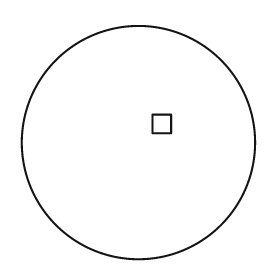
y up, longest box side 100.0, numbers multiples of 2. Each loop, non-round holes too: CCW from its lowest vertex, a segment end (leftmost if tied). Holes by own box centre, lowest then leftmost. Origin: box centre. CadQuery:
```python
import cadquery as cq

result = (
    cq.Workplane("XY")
    .moveTo(0.0, 0.0)
    .circle(50.0)
    .moveTo(6.0, 4.0)
    .lineTo(14.0, 4.0)
    .lineTo(14.0, 12.0)
    .lineTo(6.0, 12.0)
    .close()
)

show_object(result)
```